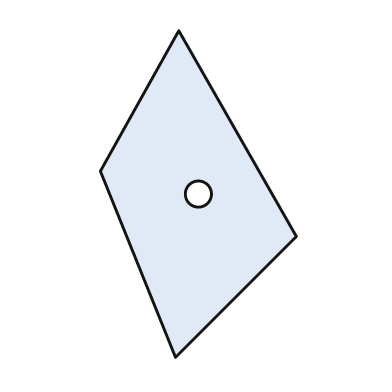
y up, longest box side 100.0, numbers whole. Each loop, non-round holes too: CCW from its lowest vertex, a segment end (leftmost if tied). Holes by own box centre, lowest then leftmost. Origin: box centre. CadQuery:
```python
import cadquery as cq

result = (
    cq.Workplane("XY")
    .moveTo(-7.0, -50.0)
    .lineTo(30.0, -13.0)
    .lineTo(-6.0, 50.0)
    .lineTo(-30.0, 7.0)
    .close()
    .moveTo(0.0, 0.0)
    .circle(4.0)
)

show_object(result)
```